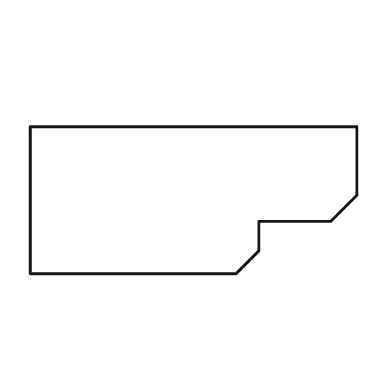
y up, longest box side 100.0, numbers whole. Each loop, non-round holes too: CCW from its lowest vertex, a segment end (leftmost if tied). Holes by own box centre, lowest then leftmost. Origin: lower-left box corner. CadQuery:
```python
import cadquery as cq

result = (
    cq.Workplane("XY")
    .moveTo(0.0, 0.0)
    .lineTo(63.0, 0.0)
    .lineTo(70.0, 7.0)
    .lineTo(70.0, 16.0)
    .lineTo(92.0, 16.0)
    .lineTo(100.0, 24.0)
    .lineTo(100.0, 45.0)
    .lineTo(0.0, 45.0)
    .close()
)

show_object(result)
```